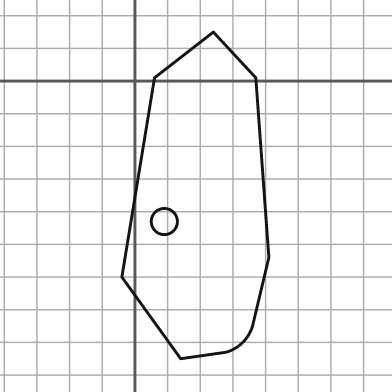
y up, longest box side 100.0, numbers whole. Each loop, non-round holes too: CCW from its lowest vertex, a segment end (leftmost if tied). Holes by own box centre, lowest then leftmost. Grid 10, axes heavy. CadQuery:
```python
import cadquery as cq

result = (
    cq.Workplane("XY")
    .moveTo(14.0, -85.0)
    .lineTo(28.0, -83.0)
    .threePointArc((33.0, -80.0), (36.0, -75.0))
    .lineTo(41.0, -54.0)
    .lineTo(37.0, 1.0)
    .lineTo(24.0, 15.0)
    .lineTo(6.0, 1.0)
    .lineTo(-4.0, -60.0)
    .close()
    .moveTo(9.0, -43.0)
    .circle(4.0)
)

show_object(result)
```